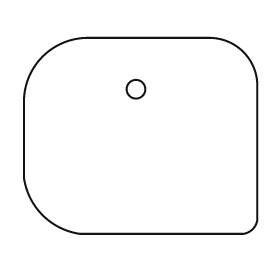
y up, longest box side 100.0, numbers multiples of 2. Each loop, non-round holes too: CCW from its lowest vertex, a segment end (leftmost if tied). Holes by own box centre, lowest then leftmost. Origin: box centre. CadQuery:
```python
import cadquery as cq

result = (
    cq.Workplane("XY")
    .moveTo(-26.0, -42.0)
    .lineTo(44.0, -42.0)
    .threePointArc((48.0, -40.0), (50.0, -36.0))
    .lineTo(50.0, 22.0)
    .threePointArc((44.0, 36.0), (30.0, 42.0))
    .lineTo(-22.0, 42.0)
    .threePointArc((-42.0, 34.0), (-50.0, 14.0))
    .lineTo(-50.0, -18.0)
    .threePointArc((-42.0, -34.0), (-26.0, -42.0))
    .close()
    .moveTo(-2.0, 20.0)
    .circle(4.0)
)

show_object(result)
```